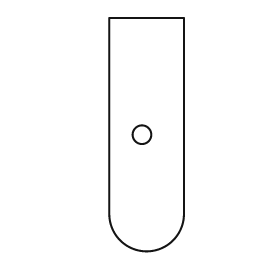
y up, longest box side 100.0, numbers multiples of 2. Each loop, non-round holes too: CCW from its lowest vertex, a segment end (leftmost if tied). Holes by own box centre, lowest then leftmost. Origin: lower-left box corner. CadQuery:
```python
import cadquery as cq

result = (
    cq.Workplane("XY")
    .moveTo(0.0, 16.0)
    .threePointArc((16.0, 0.0), (32.0, 16.0))
    .lineTo(32.0, 100.0)
    .lineTo(0.0, 100.0)
    .close()
    .moveTo(14.0, 50.0)
    .circle(4.0)
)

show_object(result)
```